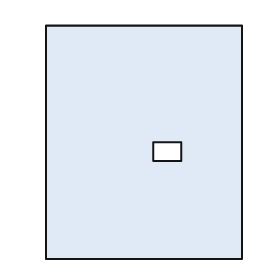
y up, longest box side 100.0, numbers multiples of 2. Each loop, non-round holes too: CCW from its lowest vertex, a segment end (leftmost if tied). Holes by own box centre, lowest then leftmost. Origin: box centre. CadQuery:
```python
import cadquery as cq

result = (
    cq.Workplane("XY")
    .moveTo(-42.0, -50.0)
    .lineTo(42.0, -50.0)
    .lineTo(42.0, 50.0)
    .lineTo(-42.0, 50.0)
    .close()
    .moveTo(4.0, -8.0)
    .lineTo(16.0, -8.0)
    .lineTo(16.0, 0.0)
    .lineTo(4.0, 0.0)
    .close()
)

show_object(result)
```